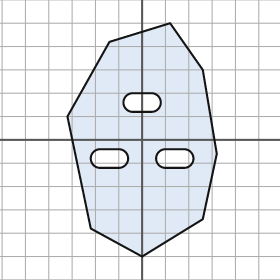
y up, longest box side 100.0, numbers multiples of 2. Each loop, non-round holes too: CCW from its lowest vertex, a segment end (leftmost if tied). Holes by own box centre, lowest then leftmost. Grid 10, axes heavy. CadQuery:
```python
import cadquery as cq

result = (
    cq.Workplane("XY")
    .moveTo(0.0, -50.0)
    .lineTo(26.0, -34.0)
    .lineTo(32.0, -6.0)
    .lineTo(26.0, 30.0)
    .lineTo(12.0, 50.0)
    .lineTo(-14.0, 42.0)
    .lineTo(-32.0, 10.0)
    .lineTo(-22.0, -38.0)
    .close()
    .moveTo(-18.0, -12.0)
    .lineTo(-10.0, -12.0)
    .threePointArc((-6.0, -8.0), (-10.0, -4.0))
    .lineTo(-18.0, -4.0)
    .threePointArc((-22.0, -8.0), (-18.0, -12.0))
    .close()
    .moveTo(10.0, -12.0)
    .lineTo(18.0, -12.0)
    .threePointArc((22.0, -8.0), (18.0, -4.0))
    .lineTo(10.0, -4.0)
    .threePointArc((6.0, -8.0), (10.0, -12.0))
    .close()
    .moveTo(-4.0, 12.0)
    .lineTo(4.0, 12.0)
    .threePointArc((8.0, 16.0), (4.0, 20.0))
    .lineTo(-4.0, 20.0)
    .threePointArc((-8.0, 16.0), (-4.0, 12.0))
    .close()
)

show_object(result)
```